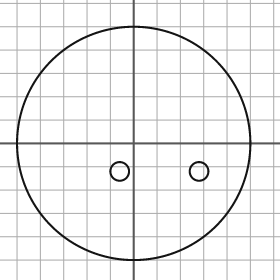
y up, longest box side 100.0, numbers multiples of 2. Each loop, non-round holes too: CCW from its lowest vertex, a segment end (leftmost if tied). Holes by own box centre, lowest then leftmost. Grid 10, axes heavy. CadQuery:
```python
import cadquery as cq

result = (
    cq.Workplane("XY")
    .moveTo(0.0, 0.0)
    .circle(50.0)
    .moveTo(-6.0, -12.0)
    .circle(4.0)
    .moveTo(28.0, -12.0)
    .circle(4.0)
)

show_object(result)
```